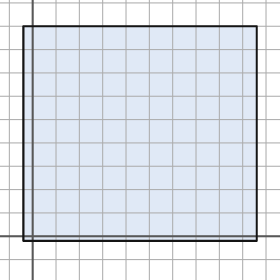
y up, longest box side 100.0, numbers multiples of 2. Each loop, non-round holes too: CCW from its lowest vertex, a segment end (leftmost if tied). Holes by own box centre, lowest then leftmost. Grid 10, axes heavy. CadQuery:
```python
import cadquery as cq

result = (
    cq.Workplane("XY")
    .moveTo(-4.0, -2.0)
    .lineTo(96.0, -2.0)
    .lineTo(96.0, 90.0)
    .lineTo(-4.0, 90.0)
    .close()
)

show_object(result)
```